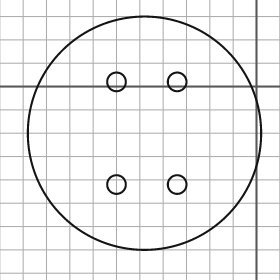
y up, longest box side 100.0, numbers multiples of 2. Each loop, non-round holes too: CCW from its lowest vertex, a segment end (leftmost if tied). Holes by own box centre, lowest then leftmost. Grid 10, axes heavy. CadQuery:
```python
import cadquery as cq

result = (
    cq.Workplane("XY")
    .moveTo(-48.0, -20.0)
    .circle(50.0)
    .moveTo(-60.0, -42.0)
    .circle(4.0)
    .moveTo(-34.0, -42.0)
    .circle(4.0)
    .moveTo(-60.0, 2.0)
    .circle(4.0)
    .moveTo(-34.0, 2.0)
    .circle(4.0)
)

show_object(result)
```